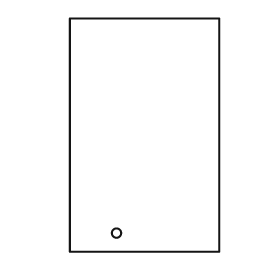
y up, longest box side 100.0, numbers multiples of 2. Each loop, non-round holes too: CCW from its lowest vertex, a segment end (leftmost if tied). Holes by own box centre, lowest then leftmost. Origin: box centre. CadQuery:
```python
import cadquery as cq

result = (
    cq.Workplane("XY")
    .moveTo(-32.0, -50.0)
    .lineTo(32.0, -50.0)
    .lineTo(32.0, 50.0)
    .lineTo(-32.0, 50.0)
    .close()
    .moveTo(-12.0, -42.0)
    .circle(2.0)
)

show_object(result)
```